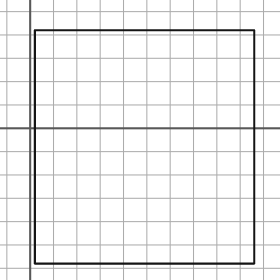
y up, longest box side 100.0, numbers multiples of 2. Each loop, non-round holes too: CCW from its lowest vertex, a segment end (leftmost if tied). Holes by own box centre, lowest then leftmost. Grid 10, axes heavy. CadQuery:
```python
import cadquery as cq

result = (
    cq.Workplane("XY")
    .moveTo(2.0, -58.0)
    .lineTo(96.0, -58.0)
    .lineTo(96.0, 42.0)
    .lineTo(2.0, 42.0)
    .close()
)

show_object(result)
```